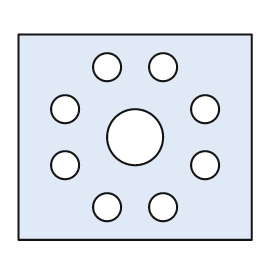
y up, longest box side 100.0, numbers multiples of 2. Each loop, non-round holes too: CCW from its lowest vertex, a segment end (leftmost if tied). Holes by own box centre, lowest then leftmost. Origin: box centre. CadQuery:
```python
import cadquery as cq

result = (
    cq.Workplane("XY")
    .moveTo(-50.0, -44.0)
    .lineTo(50.0, -44.0)
    .lineTo(50.0, 44.0)
    .lineTo(-50.0, 44.0)
    .close()
    .moveTo(-12.0, -30.0)
    .circle(6.0)
    .moveTo(12.0, -30.0)
    .circle(6.0)
    .moveTo(-30.0, -12.0)
    .circle(6.0)
    .moveTo(30.0, -12.0)
    .circle(6.0)
    .moveTo(0.0, 0.0)
    .circle(12.0)
    .moveTo(-30.0, 12.0)
    .circle(6.0)
    .moveTo(30.0, 12.0)
    .circle(6.0)
    .moveTo(-12.0, 30.0)
    .circle(6.0)
    .moveTo(12.0, 30.0)
    .circle(6.0)
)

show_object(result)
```